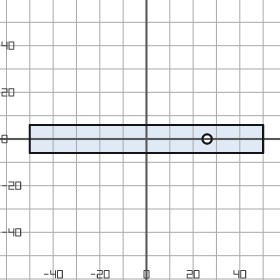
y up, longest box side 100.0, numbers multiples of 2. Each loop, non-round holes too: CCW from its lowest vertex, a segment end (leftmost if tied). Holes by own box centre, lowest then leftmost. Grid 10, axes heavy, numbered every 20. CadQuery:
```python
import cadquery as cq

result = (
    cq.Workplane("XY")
    .moveTo(-50.0, -6.0)
    .lineTo(50.0, -6.0)
    .lineTo(50.0, 6.0)
    .lineTo(-50.0, 6.0)
    .close()
    .moveTo(26.0, 0.0)
    .circle(2.0)
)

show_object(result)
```